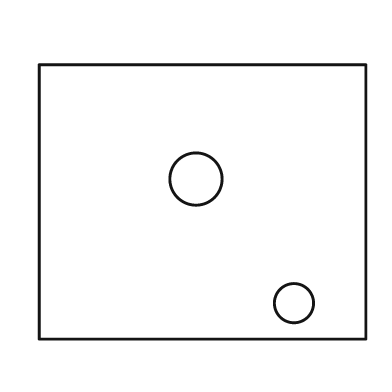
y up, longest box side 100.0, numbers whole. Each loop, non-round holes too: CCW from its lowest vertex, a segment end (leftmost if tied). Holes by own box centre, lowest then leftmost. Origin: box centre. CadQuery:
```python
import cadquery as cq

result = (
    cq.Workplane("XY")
    .moveTo(-50.0, -42.0)
    .lineTo(50.0, -42.0)
    .lineTo(50.0, 42.0)
    .lineTo(-50.0, 42.0)
    .close()
    .moveTo(28.0, -31.0)
    .circle(6.0)
    .moveTo(-2.0, 7.0)
    .circle(8.0)
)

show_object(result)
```